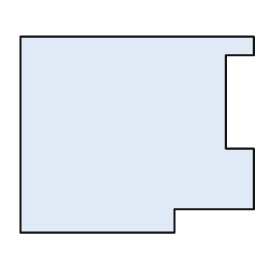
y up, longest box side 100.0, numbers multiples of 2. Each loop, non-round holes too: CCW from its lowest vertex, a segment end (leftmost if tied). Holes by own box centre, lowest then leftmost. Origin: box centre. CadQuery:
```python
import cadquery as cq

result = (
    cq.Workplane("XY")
    .moveTo(-50.0, -42.0)
    .lineTo(16.0, -42.0)
    .lineTo(16.0, -32.0)
    .lineTo(50.0, -32.0)
    .lineTo(50.0, -6.0)
    .lineTo(38.0, -6.0)
    .lineTo(38.0, 34.0)
    .lineTo(50.0, 34.0)
    .lineTo(50.0, 42.0)
    .lineTo(-50.0, 42.0)
    .close()
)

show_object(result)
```